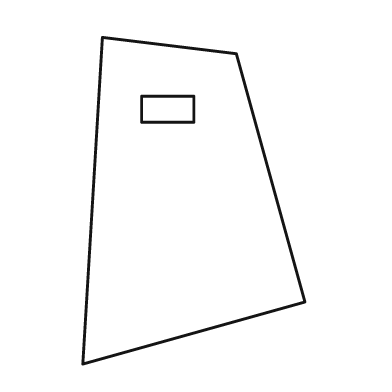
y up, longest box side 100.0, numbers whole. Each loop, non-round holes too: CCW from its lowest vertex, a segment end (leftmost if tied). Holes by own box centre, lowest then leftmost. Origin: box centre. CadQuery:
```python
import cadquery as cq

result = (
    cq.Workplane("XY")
    .moveTo(-34.0, -50.0)
    .lineTo(34.0, -31.0)
    .lineTo(13.0, 45.0)
    .lineTo(-28.0, 50.0)
    .close()
    .moveTo(-16.0, 24.0)
    .lineTo(0.0, 24.0)
    .lineTo(0.0, 32.0)
    .lineTo(-16.0, 32.0)
    .close()
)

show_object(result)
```